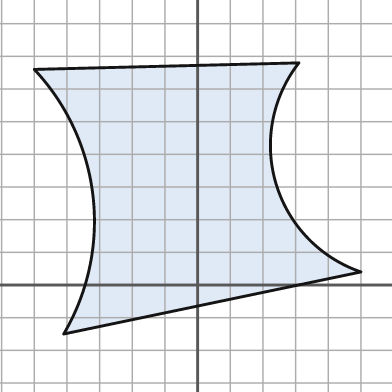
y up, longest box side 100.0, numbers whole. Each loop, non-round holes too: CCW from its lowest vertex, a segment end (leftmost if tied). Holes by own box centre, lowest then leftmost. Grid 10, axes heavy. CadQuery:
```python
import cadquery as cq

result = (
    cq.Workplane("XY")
    .moveTo(-41.0, -15.0)
    .lineTo(50.0, 4.0)
    .threePointArc((24.0, 31.0), (31.0, 68.0))
    .lineTo(-50.0, 66.0)
    .threePointArc((-32.0, 27.0), (-41.0, -15.0))
    .close()
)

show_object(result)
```